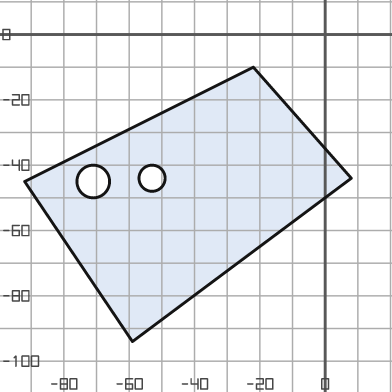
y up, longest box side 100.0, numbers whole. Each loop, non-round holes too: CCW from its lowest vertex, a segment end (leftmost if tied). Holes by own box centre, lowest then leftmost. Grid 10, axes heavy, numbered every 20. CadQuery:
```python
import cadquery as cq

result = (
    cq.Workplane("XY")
    .moveTo(-59.0, -94.0)
    .lineTo(8.0, -44.0)
    .lineTo(-22.0, -10.0)
    .lineTo(-92.0, -45.0)
    .close()
    .moveTo(-71.0, -45.0)
    .circle(5.0)
    .moveTo(-53.0, -44.0)
    .circle(4.0)
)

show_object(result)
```